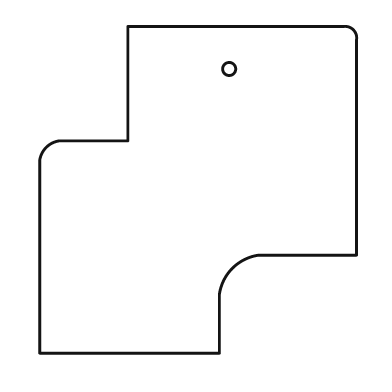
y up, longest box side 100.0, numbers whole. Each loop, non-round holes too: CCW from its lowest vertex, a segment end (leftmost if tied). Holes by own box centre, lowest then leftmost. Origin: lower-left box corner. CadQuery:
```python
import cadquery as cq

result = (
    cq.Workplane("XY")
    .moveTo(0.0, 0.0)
    .lineTo(55.0, 0.0)
    .lineTo(55.0, 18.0)
    .threePointArc((59.0, 26.0), (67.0, 30.0))
    .lineTo(97.0, 30.0)
    .lineTo(97.0, 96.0)
    .threePointArc((96.0, 99.0), (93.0, 100.0))
    .lineTo(27.0, 100.0)
    .lineTo(27.0, 65.0)
    .lineTo(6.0, 65.0)
    .threePointArc((2.0, 63.0), (0.0, 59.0))
    .close()
    .moveTo(58.0, 87.0)
    .circle(2.0)
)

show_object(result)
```